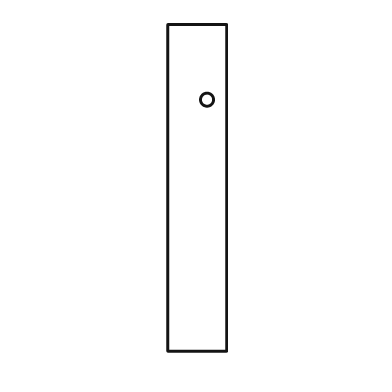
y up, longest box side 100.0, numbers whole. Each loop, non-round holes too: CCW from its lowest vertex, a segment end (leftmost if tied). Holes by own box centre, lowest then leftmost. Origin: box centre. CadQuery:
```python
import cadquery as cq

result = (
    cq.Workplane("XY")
    .moveTo(-9.0, -50.0)
    .lineTo(9.0, -50.0)
    .lineTo(9.0, 50.0)
    .lineTo(-9.0, 50.0)
    .close()
    .moveTo(3.0, 27.0)
    .circle(2.0)
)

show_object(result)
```